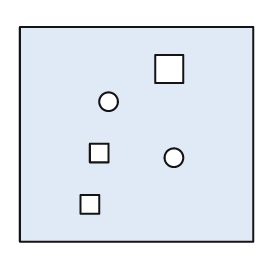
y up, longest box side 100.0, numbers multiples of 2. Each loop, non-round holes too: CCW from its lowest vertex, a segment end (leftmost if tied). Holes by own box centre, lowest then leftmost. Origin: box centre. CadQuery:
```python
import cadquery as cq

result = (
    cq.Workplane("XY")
    .moveTo(-50.0, -46.0)
    .lineTo(50.0, -46.0)
    .lineTo(50.0, 46.0)
    .lineTo(-50.0, 46.0)
    .close()
    .moveTo(-24.0, -34.0)
    .lineTo(-16.0, -34.0)
    .lineTo(-16.0, -26.0)
    .lineTo(-24.0, -26.0)
    .close()
    .moveTo(16.0, -10.0)
    .circle(4.0)
    .moveTo(-20.0, -12.0)
    .lineTo(-12.0, -12.0)
    .lineTo(-12.0, -4.0)
    .lineTo(-20.0, -4.0)
    .close()
    .moveTo(-12.0, 14.0)
    .circle(4.0)
    .moveTo(8.0, 22.0)
    .lineTo(20.0, 22.0)
    .lineTo(20.0, 34.0)
    .lineTo(8.0, 34.0)
    .close()
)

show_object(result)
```